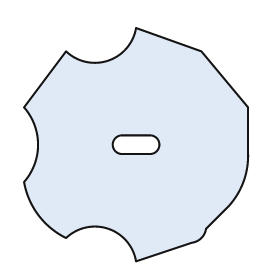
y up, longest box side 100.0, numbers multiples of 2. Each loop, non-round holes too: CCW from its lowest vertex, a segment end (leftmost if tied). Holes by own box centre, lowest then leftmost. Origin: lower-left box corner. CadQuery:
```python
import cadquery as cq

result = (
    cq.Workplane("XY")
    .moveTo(48.0, 0.0)
    .lineTo(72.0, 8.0)
    .threePointArc((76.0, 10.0), (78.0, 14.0))
    .lineTo(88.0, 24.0)
    .threePointArc((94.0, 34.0), (96.0, 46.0))
    .lineTo(96.0, 66.0)
    .lineTo(76.0, 90.0)
    .lineTo(48.0, 100.0)
    .threePointArc((36.0, 86.0), (18.0, 90.0))
    .lineTo(0.0, 66.0)
    .threePointArc((6.0, 50.0), (0.0, 34.0))
    .threePointArc((6.0, 20.0), (18.0, 10.0))
    .threePointArc((36.0, 14.0), (48.0, 0.0))
    .close()
    .moveTo(42.0, 46.0)
    .lineTo(54.0, 46.0)
    .threePointArc((58.0, 50.0), (54.0, 54.0))
    .lineTo(42.0, 54.0)
    .threePointArc((38.0, 50.0), (42.0, 46.0))
    .close()
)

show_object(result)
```